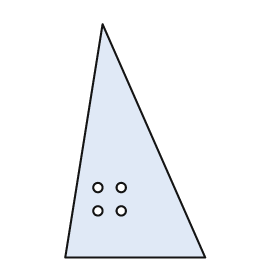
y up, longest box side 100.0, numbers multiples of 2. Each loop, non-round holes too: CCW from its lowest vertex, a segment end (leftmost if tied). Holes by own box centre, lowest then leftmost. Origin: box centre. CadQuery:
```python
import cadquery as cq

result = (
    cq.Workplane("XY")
    .moveTo(-30.0, -50.0)
    .lineTo(30.0, -50.0)
    .lineTo(-14.0, 50.0)
    .close()
    .moveTo(-16.0, -30.0)
    .circle(2.0)
    .moveTo(-6.0, -30.0)
    .circle(2.0)
    .moveTo(-16.0, -20.0)
    .circle(2.0)
    .moveTo(-6.0, -20.0)
    .circle(2.0)
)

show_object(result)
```